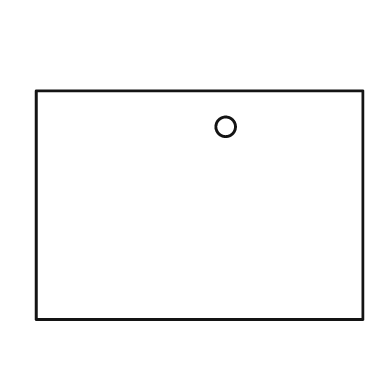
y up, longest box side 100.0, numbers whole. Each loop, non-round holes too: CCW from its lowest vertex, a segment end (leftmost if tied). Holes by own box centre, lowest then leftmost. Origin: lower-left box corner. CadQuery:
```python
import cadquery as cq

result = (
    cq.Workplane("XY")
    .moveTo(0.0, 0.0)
    .lineTo(100.0, 0.0)
    .lineTo(100.0, 70.0)
    .lineTo(0.0, 70.0)
    .close()
    .moveTo(58.0, 59.0)
    .circle(3.0)
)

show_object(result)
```